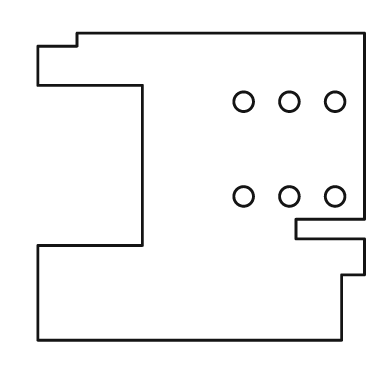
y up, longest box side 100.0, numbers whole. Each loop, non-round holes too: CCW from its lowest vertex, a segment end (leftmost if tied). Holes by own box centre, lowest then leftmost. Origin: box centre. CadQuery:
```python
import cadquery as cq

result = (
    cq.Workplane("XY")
    .moveTo(-50.0, -47.0)
    .lineTo(43.0, -47.0)
    .lineTo(43.0, -27.0)
    .lineTo(50.0, -27.0)
    .lineTo(50.0, -16.0)
    .lineTo(29.0, -16.0)
    .lineTo(29.0, -10.0)
    .lineTo(50.0, -10.0)
    .lineTo(50.0, 47.0)
    .lineTo(-38.0, 47.0)
    .lineTo(-38.0, 43.0)
    .lineTo(-50.0, 43.0)
    .lineTo(-50.0, 31.0)
    .lineTo(-18.0, 31.0)
    .lineTo(-18.0, -18.0)
    .lineTo(-50.0, -18.0)
    .close()
    .moveTo(13.0, -3.0)
    .circle(3.0)
    .moveTo(27.0, -3.0)
    .circle(3.0)
    .moveTo(41.0, -3.0)
    .circle(3.0)
    .moveTo(13.0, 26.0)
    .circle(3.0)
    .moveTo(27.0, 26.0)
    .circle(3.0)
    .moveTo(41.0, 26.0)
    .circle(3.0)
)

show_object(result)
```